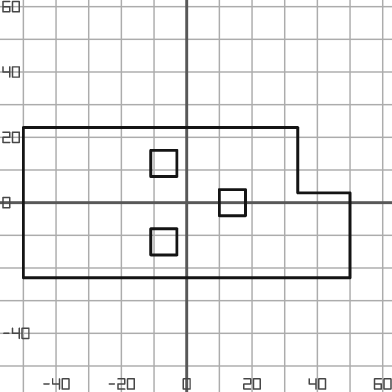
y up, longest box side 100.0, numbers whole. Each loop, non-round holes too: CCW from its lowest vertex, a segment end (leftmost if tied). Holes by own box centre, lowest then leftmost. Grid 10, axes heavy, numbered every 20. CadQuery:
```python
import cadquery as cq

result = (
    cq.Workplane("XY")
    .moveTo(-50.0, -23.0)
    .lineTo(50.0, -23.0)
    .lineTo(50.0, 3.0)
    .lineTo(34.0, 3.0)
    .lineTo(34.0, 23.0)
    .lineTo(-50.0, 23.0)
    .close()
    .moveTo(-11.0, -16.0)
    .lineTo(-3.0, -16.0)
    .lineTo(-3.0, -8.0)
    .lineTo(-11.0, -8.0)
    .close()
    .moveTo(10.0, -4.0)
    .lineTo(18.0, -4.0)
    .lineTo(18.0, 4.0)
    .lineTo(10.0, 4.0)
    .close()
    .moveTo(-11.0, 8.0)
    .lineTo(-3.0, 8.0)
    .lineTo(-3.0, 16.0)
    .lineTo(-11.0, 16.0)
    .close()
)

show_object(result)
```